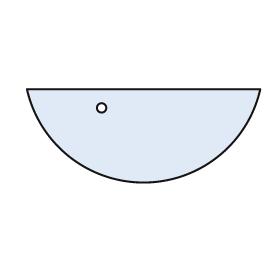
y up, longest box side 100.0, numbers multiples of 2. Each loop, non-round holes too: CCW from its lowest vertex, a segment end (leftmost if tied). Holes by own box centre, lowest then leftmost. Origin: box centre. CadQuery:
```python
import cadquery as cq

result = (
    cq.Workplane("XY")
    .moveTo(-50.0, 20.0)
    .threePointArc((0.0, -20.0), (50.0, 20.0))
    .close()
    .moveTo(-18.0, 12.0)
    .circle(2.0)
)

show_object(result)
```